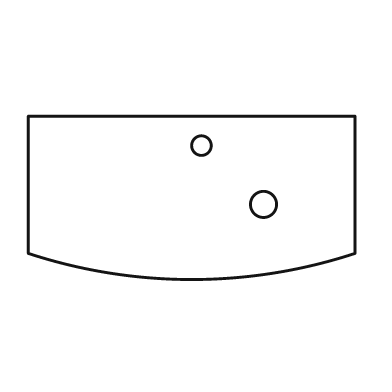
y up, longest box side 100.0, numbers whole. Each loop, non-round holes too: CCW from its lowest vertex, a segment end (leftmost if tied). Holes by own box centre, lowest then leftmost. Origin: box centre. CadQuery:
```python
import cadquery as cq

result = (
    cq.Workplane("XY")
    .moveTo(-50.0, -17.0)
    .threePointArc((0.0, -25.0), (50.0, -17.0))
    .lineTo(50.0, 25.0)
    .lineTo(-50.0, 25.0)
    .close()
    .moveTo(22.0, -2.0)
    .circle(4.0)
    .moveTo(3.0, 16.0)
    .circle(3.0)
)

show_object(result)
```